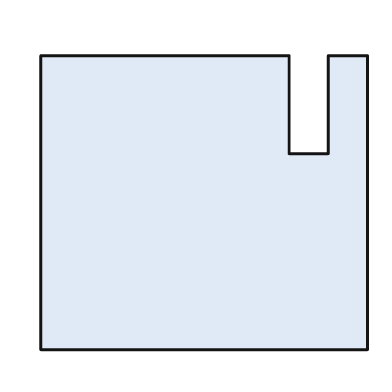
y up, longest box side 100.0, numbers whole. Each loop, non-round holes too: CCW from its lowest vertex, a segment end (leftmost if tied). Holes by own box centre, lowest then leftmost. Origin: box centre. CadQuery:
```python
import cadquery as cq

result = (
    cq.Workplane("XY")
    .moveTo(-50.0, -45.0)
    .lineTo(50.0, -45.0)
    .lineTo(50.0, 45.0)
    .lineTo(38.0, 45.0)
    .lineTo(38.0, 15.0)
    .lineTo(26.0, 15.0)
    .lineTo(26.0, 45.0)
    .lineTo(-50.0, 45.0)
    .close()
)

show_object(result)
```